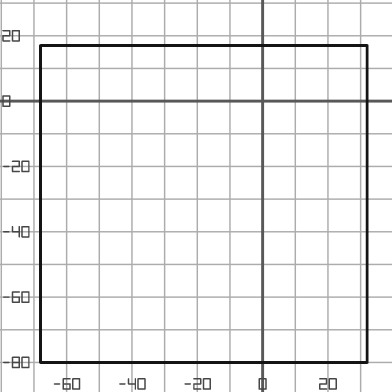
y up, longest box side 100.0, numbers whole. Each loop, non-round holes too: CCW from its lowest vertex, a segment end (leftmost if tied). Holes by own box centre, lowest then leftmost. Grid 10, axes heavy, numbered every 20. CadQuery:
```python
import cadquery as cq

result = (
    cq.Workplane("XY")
    .moveTo(-68.0, -80.0)
    .lineTo(32.0, -80.0)
    .lineTo(32.0, 17.0)
    .lineTo(-68.0, 17.0)
    .close()
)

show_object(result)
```